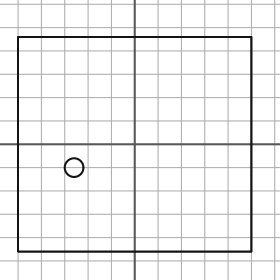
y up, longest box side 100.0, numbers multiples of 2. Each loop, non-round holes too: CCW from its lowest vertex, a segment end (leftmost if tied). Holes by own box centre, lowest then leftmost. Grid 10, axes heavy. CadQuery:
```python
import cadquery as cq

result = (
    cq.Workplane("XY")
    .moveTo(-50.0, -46.0)
    .lineTo(50.0, -46.0)
    .lineTo(50.0, 46.0)
    .lineTo(-50.0, 46.0)
    .close()
    .moveTo(-26.0, -10.0)
    .circle(4.0)
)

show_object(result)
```